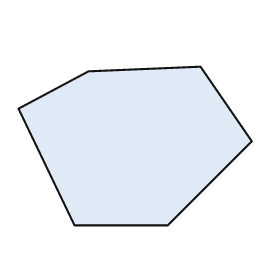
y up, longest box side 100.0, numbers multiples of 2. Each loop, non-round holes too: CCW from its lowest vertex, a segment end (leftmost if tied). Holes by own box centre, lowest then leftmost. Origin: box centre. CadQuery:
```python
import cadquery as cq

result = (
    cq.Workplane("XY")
    .moveTo(-26.0, -34.0)
    .lineTo(14.0, -34.0)
    .lineTo(50.0, 2.0)
    .lineTo(28.0, 34.0)
    .lineTo(-20.0, 32.0)
    .lineTo(-50.0, 16.0)
    .close()
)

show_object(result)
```